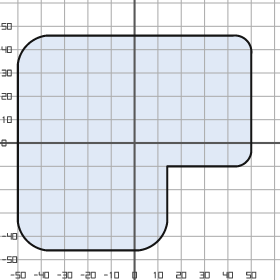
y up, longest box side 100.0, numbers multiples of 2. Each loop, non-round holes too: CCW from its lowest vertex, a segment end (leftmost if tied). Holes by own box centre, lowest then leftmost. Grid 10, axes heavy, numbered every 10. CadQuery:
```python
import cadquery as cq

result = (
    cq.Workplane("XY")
    .moveTo(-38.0, -46.0)
    .lineTo(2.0, -46.0)
    .threePointArc((10.0, -42.0), (14.0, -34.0))
    .lineTo(14.0, -10.0)
    .lineTo(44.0, -10.0)
    .threePointArc((48.0, -8.0), (50.0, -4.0))
    .lineTo(50.0, 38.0)
    .threePointArc((48.0, 44.0), (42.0, 46.0))
    .lineTo(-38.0, 46.0)
    .threePointArc((-46.0, 42.0), (-50.0, 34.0))
    .lineTo(-50.0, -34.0)
    .threePointArc((-46.0, -42.0), (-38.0, -46.0))
    .close()
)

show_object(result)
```